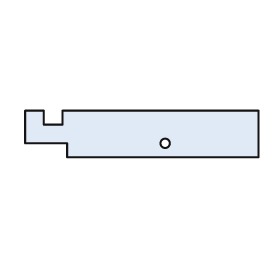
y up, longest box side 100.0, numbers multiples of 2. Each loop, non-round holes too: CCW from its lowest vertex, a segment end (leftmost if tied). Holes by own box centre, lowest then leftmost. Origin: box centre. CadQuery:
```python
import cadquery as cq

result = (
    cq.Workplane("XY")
    .moveTo(-32.0, -10.0)
    .lineTo(50.0, -10.0)
    .lineTo(50.0, 10.0)
    .lineTo(-34.0, 10.0)
    .lineTo(-34.0, 4.0)
    .lineTo(-42.0, 4.0)
    .lineTo(-42.0, 10.0)
    .lineTo(-50.0, 10.0)
    .lineTo(-50.0, -4.0)
    .lineTo(-32.0, -4.0)
    .close()
    .moveTo(10.0, -4.0)
    .circle(2.0)
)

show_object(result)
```